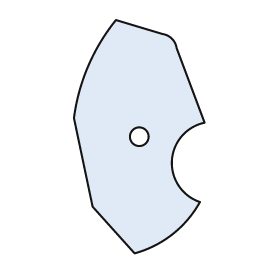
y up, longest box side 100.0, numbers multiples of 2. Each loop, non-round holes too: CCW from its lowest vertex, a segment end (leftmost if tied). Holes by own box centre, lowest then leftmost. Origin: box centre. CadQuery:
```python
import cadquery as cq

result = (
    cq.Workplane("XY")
    .moveTo(-2.0, -50.0)
    .threePointArc((14.0, -42.0), (26.0, -28.0))
    .threePointArc((14.0, -10.0), (28.0, 6.0))
    .lineTo(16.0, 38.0)
    .threePointArc((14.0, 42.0), (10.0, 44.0))
    .lineTo(-10.0, 50.0)
    .threePointArc((-22.0, 30.0), (-28.0, 8.0))
    .lineTo(-20.0, -30.0)
    .close()
    .moveTo(0.0, 0.0)
    .circle(4.0)
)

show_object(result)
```